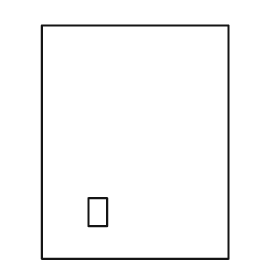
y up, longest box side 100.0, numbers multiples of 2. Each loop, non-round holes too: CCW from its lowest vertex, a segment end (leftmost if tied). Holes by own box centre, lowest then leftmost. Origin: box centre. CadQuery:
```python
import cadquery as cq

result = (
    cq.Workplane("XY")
    .moveTo(-40.0, -50.0)
    .lineTo(40.0, -50.0)
    .lineTo(40.0, 50.0)
    .lineTo(-40.0, 50.0)
    .close()
    .moveTo(-20.0, -36.0)
    .lineTo(-12.0, -36.0)
    .lineTo(-12.0, -24.0)
    .lineTo(-20.0, -24.0)
    .close()
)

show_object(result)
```